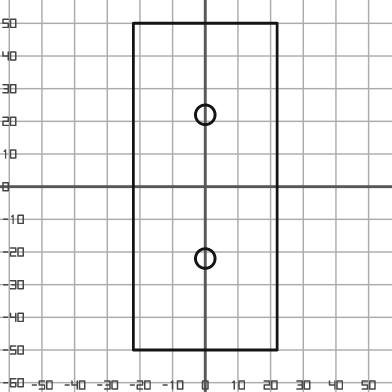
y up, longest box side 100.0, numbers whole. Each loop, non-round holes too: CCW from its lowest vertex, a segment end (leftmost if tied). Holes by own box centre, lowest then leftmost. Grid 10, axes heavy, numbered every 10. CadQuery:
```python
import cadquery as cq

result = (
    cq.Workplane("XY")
    .moveTo(-22.0, -50.0)
    .lineTo(22.0, -50.0)
    .lineTo(22.0, 50.0)
    .lineTo(-22.0, 50.0)
    .close()
    .moveTo(0.0, -22.0)
    .circle(3.0)
    .moveTo(0.0, 22.0)
    .circle(3.0)
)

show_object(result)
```